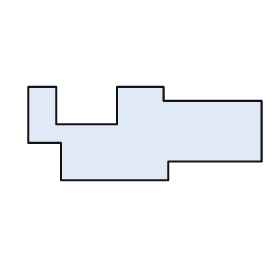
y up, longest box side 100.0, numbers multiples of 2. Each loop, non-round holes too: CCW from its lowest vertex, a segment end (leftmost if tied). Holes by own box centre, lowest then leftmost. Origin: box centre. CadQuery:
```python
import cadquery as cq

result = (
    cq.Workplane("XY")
    .moveTo(-36.0, -20.0)
    .lineTo(10.0, -20.0)
    .lineTo(10.0, -12.0)
    .lineTo(50.0, -12.0)
    .lineTo(50.0, 14.0)
    .lineTo(8.0, 14.0)
    .lineTo(8.0, 20.0)
    .lineTo(-12.0, 20.0)
    .lineTo(-12.0, 4.0)
    .lineTo(-38.0, 4.0)
    .lineTo(-38.0, 20.0)
    .lineTo(-50.0, 20.0)
    .lineTo(-50.0, -4.0)
    .lineTo(-36.0, -4.0)
    .close()
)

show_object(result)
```